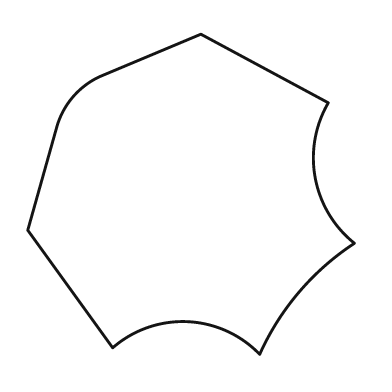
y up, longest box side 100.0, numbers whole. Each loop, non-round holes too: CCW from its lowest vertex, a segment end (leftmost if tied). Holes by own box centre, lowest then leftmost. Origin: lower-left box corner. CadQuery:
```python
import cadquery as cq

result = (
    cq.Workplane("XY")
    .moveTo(71.0, 0.0)
    .threePointArc((83.0, 19.0), (100.0, 34.0))
    .threePointArc((88.0, 54.0), (92.0, 77.0))
    .lineTo(53.0, 98.0)
    .lineTo(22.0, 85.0)
    .threePointArc((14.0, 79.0), (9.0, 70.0))
    .lineTo(0.0, 38.0)
    .lineTo(26.0, 2.0)
    .threePointArc((49.0, 10.0), (71.0, 0.0))
    .close()
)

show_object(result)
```